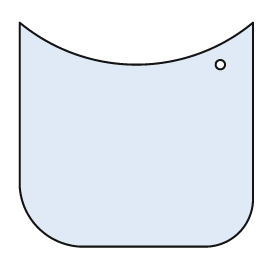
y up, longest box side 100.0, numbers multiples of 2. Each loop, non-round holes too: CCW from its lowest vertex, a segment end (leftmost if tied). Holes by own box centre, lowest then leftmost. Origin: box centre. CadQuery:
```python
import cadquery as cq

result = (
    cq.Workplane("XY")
    .moveTo(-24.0, -48.0)
    .lineTo(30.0, -48.0)
    .threePointArc((44.0, -42.0), (50.0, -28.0))
    .lineTo(50.0, 48.0)
    .threePointArc((0.0, 30.0), (-50.0, 48.0))
    .lineTo(-50.0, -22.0)
    .threePointArc((-42.0, -40.0), (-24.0, -48.0))
    .close()
    .moveTo(36.0, 30.0)
    .circle(2.0)
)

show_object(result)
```